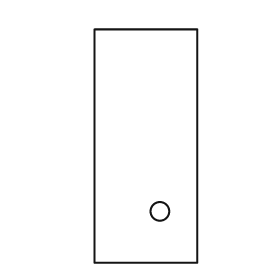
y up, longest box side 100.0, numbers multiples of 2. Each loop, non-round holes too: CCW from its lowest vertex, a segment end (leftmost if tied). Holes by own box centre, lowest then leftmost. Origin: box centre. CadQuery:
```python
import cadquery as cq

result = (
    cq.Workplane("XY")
    .moveTo(-22.0, -50.0)
    .lineTo(22.0, -50.0)
    .lineTo(22.0, 50.0)
    .lineTo(-22.0, 50.0)
    .close()
    .moveTo(6.0, -28.0)
    .circle(4.0)
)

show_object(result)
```